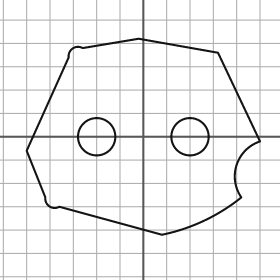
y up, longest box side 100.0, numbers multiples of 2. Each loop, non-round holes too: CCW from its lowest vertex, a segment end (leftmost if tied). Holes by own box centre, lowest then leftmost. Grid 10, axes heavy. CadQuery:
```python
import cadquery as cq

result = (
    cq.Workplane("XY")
    .moveTo(8.0, -42.0)
    .threePointArc((26.0, -36.0), (42.0, -26.0))
    .threePointArc((40.0, -12.0), (50.0, -2.0))
    .lineTo(32.0, 36.0)
    .lineTo(-2.0, 42.0)
    .lineTo(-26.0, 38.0)
    .threePointArc((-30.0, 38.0), (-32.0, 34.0))
    .lineTo(-50.0, -6.0)
    .lineTo(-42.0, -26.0)
    .threePointArc((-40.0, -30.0), (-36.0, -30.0))
    .close()
    .moveTo(-20.0, 0.0)
    .circle(8.0)
    .moveTo(20.0, 0.0)
    .circle(8.0)
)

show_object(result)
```